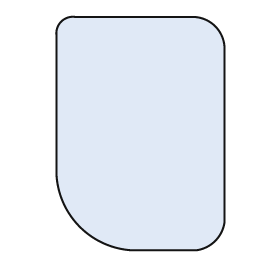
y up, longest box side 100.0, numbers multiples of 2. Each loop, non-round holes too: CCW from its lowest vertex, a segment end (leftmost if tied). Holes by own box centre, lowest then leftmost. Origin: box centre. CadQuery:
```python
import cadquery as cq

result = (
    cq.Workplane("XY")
    .moveTo(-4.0, -50.0)
    .lineTo(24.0, -50.0)
    .threePointArc((32.0, -46.0), (36.0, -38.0))
    .lineTo(36.0, 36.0)
    .threePointArc((32.0, 46.0), (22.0, 50.0))
    .lineTo(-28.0, 50.0)
    .threePointArc((-34.0, 48.0), (-36.0, 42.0))
    .lineTo(-36.0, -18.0)
    .threePointArc((-26.0, -40.0), (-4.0, -50.0))
    .close()
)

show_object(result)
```